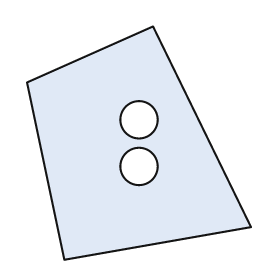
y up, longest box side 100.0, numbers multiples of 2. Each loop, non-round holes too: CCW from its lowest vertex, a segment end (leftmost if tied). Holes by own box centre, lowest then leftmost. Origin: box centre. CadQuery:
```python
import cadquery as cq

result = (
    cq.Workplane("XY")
    .moveTo(-32.0, -50.0)
    .lineTo(48.0, -36.0)
    .lineTo(6.0, 50.0)
    .lineTo(-48.0, 26.0)
    .close()
    .moveTo(0.0, -10.0)
    .circle(8.0)
    .moveTo(0.0, 10.0)
    .circle(8.0)
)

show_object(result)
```